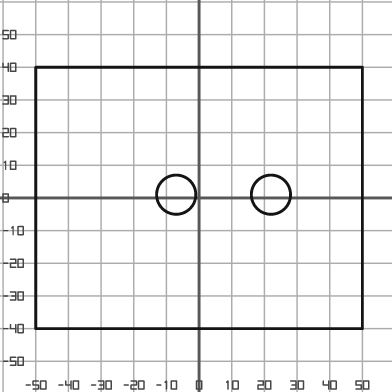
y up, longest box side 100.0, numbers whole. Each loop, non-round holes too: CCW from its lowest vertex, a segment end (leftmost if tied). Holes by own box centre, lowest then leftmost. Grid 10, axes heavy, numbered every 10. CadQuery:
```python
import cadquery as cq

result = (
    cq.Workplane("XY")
    .moveTo(-50.0, -40.0)
    .lineTo(50.0, -40.0)
    .lineTo(50.0, 40.0)
    .lineTo(-50.0, 40.0)
    .close()
    .moveTo(-7.0, 1.0)
    .circle(6.0)
    .moveTo(22.0, 1.0)
    .circle(6.0)
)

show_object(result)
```